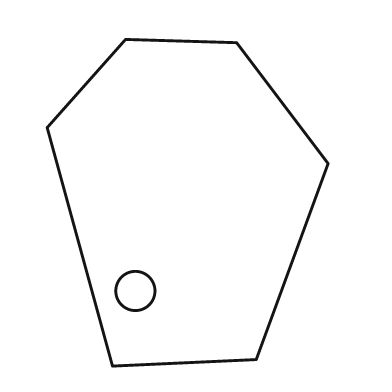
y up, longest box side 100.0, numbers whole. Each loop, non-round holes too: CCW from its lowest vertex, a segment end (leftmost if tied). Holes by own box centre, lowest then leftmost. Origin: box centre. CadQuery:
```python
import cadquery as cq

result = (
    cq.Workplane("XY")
    .moveTo(-23.0, -50.0)
    .lineTo(21.0, -48.0)
    .lineTo(43.0, 12.0)
    .lineTo(15.0, 49.0)
    .lineTo(-19.0, 50.0)
    .lineTo(-43.0, 23.0)
    .close()
    .moveTo(-16.0, -27.0)
    .circle(6.0)
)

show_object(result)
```